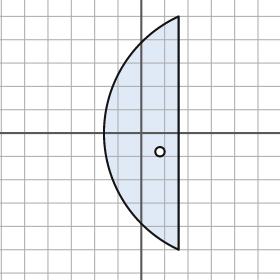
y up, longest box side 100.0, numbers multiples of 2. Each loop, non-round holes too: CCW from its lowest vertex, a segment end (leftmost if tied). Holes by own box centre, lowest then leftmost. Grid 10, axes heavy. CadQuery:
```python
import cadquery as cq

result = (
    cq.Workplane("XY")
    .moveTo(16.0, -50.0)
    .lineTo(16.0, 50.0)
    .threePointArc((-16.0, 0.0), (16.0, -50.0))
    .close()
    .moveTo(8.0, -8.0)
    .circle(2.0)
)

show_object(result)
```